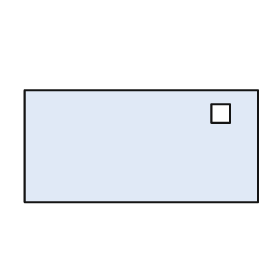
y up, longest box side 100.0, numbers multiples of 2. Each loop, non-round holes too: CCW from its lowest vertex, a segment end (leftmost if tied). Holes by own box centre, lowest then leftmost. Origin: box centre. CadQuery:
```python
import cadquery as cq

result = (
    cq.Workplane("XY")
    .moveTo(-50.0, -24.0)
    .lineTo(50.0, -24.0)
    .lineTo(50.0, 24.0)
    .lineTo(-50.0, 24.0)
    .close()
    .moveTo(30.0, 10.0)
    .lineTo(38.0, 10.0)
    .lineTo(38.0, 18.0)
    .lineTo(30.0, 18.0)
    .close()
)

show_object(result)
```